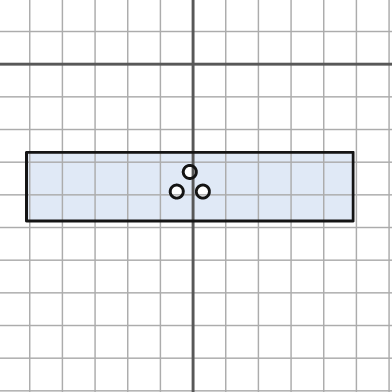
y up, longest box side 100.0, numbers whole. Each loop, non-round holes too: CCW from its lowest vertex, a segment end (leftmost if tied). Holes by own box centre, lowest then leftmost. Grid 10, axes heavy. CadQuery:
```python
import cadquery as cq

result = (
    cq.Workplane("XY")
    .moveTo(-51.0, -48.0)
    .lineTo(49.0, -48.0)
    .lineTo(49.0, -27.0)
    .lineTo(-51.0, -27.0)
    .close()
    .moveTo(-5.0, -39.0)
    .circle(2.0)
    .moveTo(3.0, -39.0)
    .circle(2.0)
    .moveTo(-1.0, -33.0)
    .circle(2.0)
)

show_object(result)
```